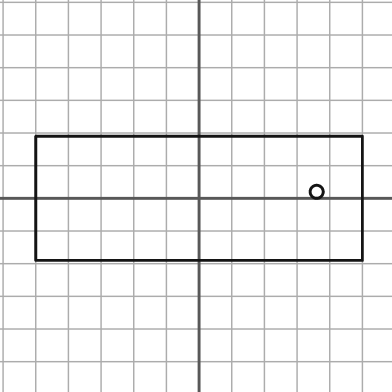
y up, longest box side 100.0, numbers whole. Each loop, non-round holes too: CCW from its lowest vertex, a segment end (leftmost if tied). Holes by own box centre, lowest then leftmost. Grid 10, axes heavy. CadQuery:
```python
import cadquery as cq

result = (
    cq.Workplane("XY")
    .moveTo(-50.0, -19.0)
    .lineTo(50.0, -19.0)
    .lineTo(50.0, 19.0)
    .lineTo(-50.0, 19.0)
    .close()
    .moveTo(36.0, 2.0)
    .circle(2.0)
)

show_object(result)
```